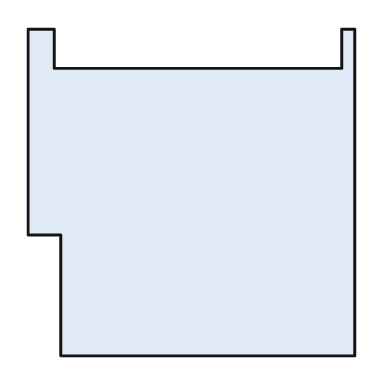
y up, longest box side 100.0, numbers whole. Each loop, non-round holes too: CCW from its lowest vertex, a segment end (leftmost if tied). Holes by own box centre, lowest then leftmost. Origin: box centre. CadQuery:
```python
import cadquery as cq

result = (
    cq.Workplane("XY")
    .moveTo(-40.0, -50.0)
    .lineTo(50.0, -50.0)
    .lineTo(50.0, 50.0)
    .lineTo(46.0, 50.0)
    .lineTo(46.0, 38.0)
    .lineTo(-42.0, 38.0)
    .lineTo(-42.0, 50.0)
    .lineTo(-50.0, 50.0)
    .lineTo(-50.0, -13.0)
    .lineTo(-40.0, -13.0)
    .close()
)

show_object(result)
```